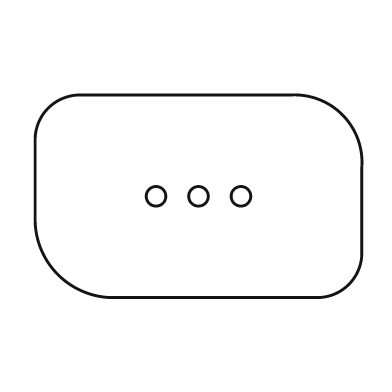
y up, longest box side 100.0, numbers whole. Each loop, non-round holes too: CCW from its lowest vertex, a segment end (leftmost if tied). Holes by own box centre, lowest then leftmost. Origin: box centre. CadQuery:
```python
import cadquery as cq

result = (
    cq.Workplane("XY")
    .moveTo(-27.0, -31.0)
    .lineTo(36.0, -31.0)
    .threePointArc((46.0, -27.0), (50.0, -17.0))
    .lineTo(50.0, 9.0)
    .threePointArc((44.0, 25.0), (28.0, 31.0))
    .lineTo(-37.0, 31.0)
    .threePointArc((-46.0, 27.0), (-50.0, 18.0))
    .lineTo(-50.0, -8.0)
    .threePointArc((-43.0, -24.0), (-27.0, -31.0))
    .close()
    .moveTo(-13.0, 0.0)
    .circle(3.0)
    .moveTo(0.0, 0.0)
    .circle(3.0)
    .moveTo(13.0, 0.0)
    .circle(3.0)
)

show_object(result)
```